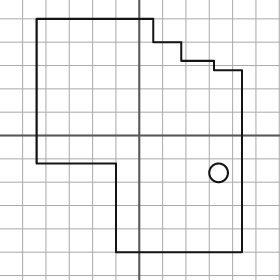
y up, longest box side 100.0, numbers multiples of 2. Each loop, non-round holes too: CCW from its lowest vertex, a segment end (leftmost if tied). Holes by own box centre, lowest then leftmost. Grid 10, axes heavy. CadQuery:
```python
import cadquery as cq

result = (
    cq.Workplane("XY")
    .moveTo(-10.0, -50.0)
    .lineTo(44.0, -50.0)
    .lineTo(44.0, 28.0)
    .lineTo(32.0, 28.0)
    .lineTo(32.0, 32.0)
    .lineTo(18.0, 32.0)
    .lineTo(18.0, 40.0)
    .lineTo(6.0, 40.0)
    .lineTo(6.0, 50.0)
    .lineTo(-44.0, 50.0)
    .lineTo(-44.0, -12.0)
    .lineTo(-10.0, -12.0)
    .close()
    .moveTo(34.0, -16.0)
    .circle(4.0)
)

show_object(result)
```